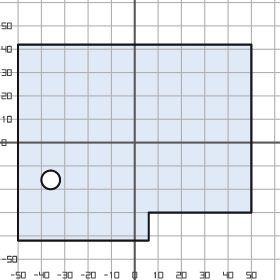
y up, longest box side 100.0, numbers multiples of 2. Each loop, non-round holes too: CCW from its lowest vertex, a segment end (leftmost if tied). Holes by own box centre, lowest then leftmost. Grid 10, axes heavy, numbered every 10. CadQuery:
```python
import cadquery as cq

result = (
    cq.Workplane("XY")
    .moveTo(-50.0, -42.0)
    .lineTo(6.0, -42.0)
    .lineTo(6.0, -30.0)
    .lineTo(50.0, -30.0)
    .lineTo(50.0, 42.0)
    .lineTo(-50.0, 42.0)
    .close()
    .moveTo(-36.0, -16.0)
    .circle(4.0)
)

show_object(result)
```